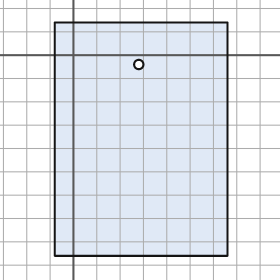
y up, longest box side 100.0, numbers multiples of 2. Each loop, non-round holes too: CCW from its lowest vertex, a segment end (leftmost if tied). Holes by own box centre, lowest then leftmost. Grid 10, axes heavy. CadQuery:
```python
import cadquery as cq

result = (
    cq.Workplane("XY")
    .moveTo(-8.0, -86.0)
    .lineTo(66.0, -86.0)
    .lineTo(66.0, 14.0)
    .lineTo(-8.0, 14.0)
    .close()
    .moveTo(28.0, -4.0)
    .circle(2.0)
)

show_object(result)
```